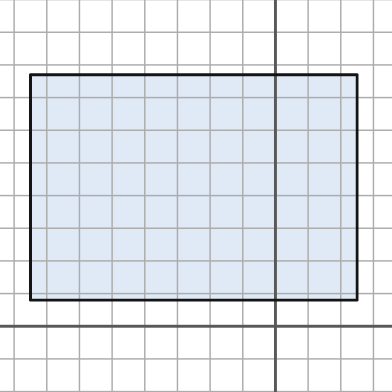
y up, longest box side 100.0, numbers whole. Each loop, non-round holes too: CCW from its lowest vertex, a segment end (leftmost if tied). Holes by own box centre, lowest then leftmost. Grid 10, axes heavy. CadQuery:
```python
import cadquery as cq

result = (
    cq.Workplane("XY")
    .moveTo(-75.0, 8.0)
    .lineTo(25.0, 8.0)
    .lineTo(25.0, 77.0)
    .lineTo(-75.0, 77.0)
    .close()
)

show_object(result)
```